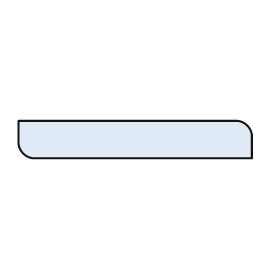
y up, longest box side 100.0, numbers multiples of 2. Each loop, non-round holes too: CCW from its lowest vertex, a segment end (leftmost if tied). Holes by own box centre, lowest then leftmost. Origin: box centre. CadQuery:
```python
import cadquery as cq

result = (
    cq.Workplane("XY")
    .moveTo(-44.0, -8.0)
    .lineTo(50.0, -8.0)
    .lineTo(50.0, 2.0)
    .threePointArc((48.0, 6.0), (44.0, 8.0))
    .lineTo(-50.0, 8.0)
    .lineTo(-50.0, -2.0)
    .threePointArc((-48.0, -6.0), (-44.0, -8.0))
    .close()
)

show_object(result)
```